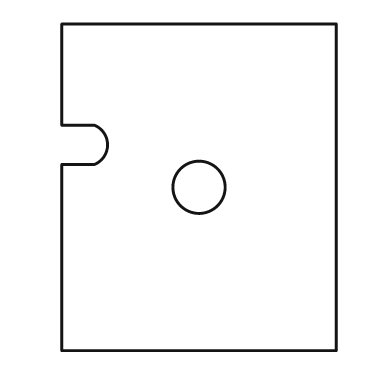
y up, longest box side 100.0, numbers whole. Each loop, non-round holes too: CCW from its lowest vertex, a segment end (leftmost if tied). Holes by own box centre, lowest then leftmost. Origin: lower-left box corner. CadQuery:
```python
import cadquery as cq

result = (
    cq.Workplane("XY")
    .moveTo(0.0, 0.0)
    .lineTo(84.0, 0.0)
    .lineTo(84.0, 100.0)
    .lineTo(0.0, 100.0)
    .lineTo(0.0, 69.0)
    .lineTo(10.0, 69.0)
    .threePointArc((14.0, 63.0), (10.0, 57.0))
    .lineTo(0.0, 57.0)
    .close()
    .moveTo(42.0, 50.0)
    .circle(8.0)
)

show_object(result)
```